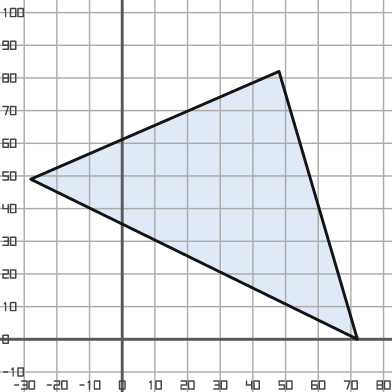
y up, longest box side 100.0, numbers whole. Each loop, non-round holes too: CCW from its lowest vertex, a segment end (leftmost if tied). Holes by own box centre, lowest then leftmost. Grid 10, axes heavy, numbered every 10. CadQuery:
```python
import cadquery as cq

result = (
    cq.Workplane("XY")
    .moveTo(72.0, 0.0)
    .lineTo(48.0, 82.0)
    .lineTo(-28.0, 49.0)
    .close()
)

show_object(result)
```